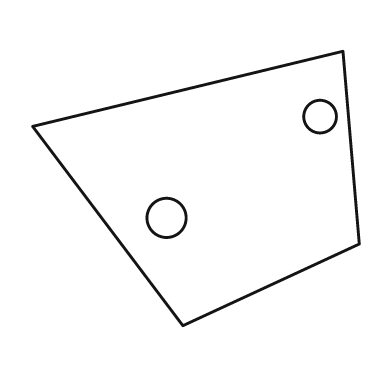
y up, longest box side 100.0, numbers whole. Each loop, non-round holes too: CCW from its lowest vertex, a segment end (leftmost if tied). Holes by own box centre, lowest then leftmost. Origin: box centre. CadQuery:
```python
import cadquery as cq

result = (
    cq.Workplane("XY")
    .moveTo(-4.0, -42.0)
    .lineTo(50.0, -17.0)
    .lineTo(45.0, 42.0)
    .lineTo(-50.0, 19.0)
    .close()
    .moveTo(-9.0, -9.0)
    .circle(6.0)
    .moveTo(38.0, 22.0)
    .circle(5.0)
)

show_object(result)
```